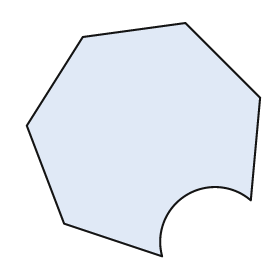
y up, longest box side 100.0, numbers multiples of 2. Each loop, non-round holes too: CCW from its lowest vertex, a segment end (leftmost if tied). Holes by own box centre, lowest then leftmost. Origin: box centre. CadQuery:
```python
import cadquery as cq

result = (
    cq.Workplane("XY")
    .moveTo(8.0, -50.0)
    .threePointArc((18.0, -24.0), (46.0, -26.0))
    .lineTo(50.0, 18.0)
    .lineTo(18.0, 50.0)
    .lineTo(-26.0, 44.0)
    .lineTo(-50.0, 6.0)
    .lineTo(-34.0, -36.0)
    .close()
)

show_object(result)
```